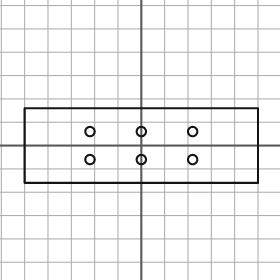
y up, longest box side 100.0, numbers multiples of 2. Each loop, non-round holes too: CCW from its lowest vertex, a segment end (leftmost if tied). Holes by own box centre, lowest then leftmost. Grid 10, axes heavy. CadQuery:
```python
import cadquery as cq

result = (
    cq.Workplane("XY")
    .moveTo(-50.0, -16.0)
    .lineTo(50.0, -16.0)
    .lineTo(50.0, 16.0)
    .lineTo(-50.0, 16.0)
    .close()
    .moveTo(-22.0, -6.0)
    .circle(2.0)
    .moveTo(0.0, -6.0)
    .circle(2.0)
    .moveTo(22.0, -6.0)
    .circle(2.0)
    .moveTo(-22.0, 6.0)
    .circle(2.0)
    .moveTo(0.0, 6.0)
    .circle(2.0)
    .moveTo(22.0, 6.0)
    .circle(2.0)
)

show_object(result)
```